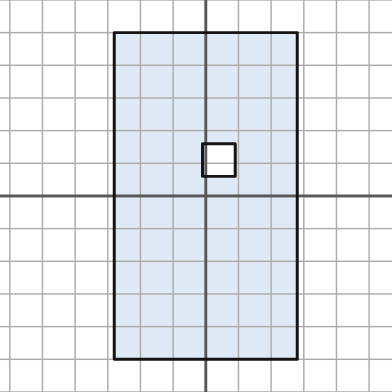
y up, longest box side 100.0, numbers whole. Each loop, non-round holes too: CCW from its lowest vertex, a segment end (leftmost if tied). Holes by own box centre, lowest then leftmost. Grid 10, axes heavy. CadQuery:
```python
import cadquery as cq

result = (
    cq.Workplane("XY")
    .moveTo(-28.0, -50.0)
    .lineTo(28.0, -50.0)
    .lineTo(28.0, 50.0)
    .lineTo(-28.0, 50.0)
    .close()
    .moveTo(-1.0, 6.0)
    .lineTo(9.0, 6.0)
    .lineTo(9.0, 16.0)
    .lineTo(-1.0, 16.0)
    .close()
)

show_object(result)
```